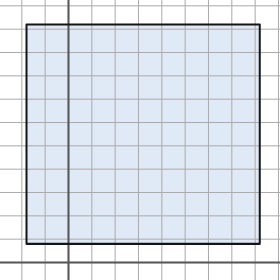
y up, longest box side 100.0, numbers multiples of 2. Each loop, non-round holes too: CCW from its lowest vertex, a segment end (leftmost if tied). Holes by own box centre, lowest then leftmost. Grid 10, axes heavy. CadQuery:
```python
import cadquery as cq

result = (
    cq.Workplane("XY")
    .moveTo(-18.0, 8.0)
    .lineTo(82.0, 8.0)
    .lineTo(82.0, 102.0)
    .lineTo(-18.0, 102.0)
    .close()
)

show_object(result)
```